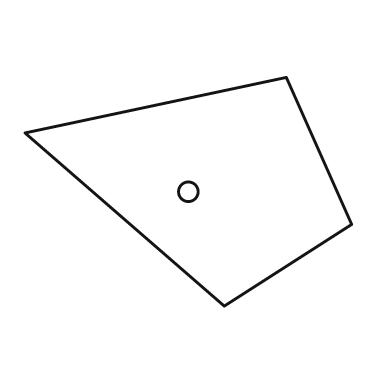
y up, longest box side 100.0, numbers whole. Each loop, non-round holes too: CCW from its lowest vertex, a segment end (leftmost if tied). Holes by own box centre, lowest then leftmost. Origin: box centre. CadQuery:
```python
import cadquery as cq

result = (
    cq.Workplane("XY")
    .moveTo(11.0, -35.0)
    .lineTo(50.0, -10.0)
    .lineTo(30.0, 35.0)
    .lineTo(-50.0, 18.0)
    .close()
    .moveTo(0.0, 0.0)
    .circle(3.0)
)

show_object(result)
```